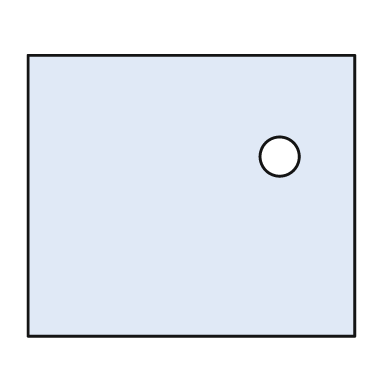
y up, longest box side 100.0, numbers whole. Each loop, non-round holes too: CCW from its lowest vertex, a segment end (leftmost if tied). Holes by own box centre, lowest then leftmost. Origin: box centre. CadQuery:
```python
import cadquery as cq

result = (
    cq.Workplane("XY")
    .moveTo(-50.0, -43.0)
    .lineTo(50.0, -43.0)
    .lineTo(50.0, 43.0)
    .lineTo(-50.0, 43.0)
    .close()
    .moveTo(27.0, 12.0)
    .circle(6.0)
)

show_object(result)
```